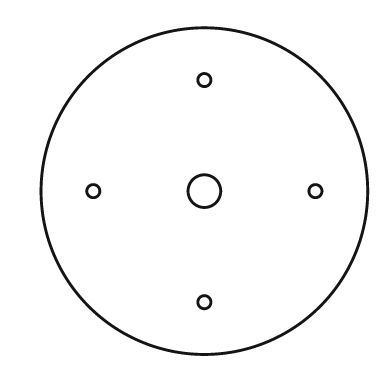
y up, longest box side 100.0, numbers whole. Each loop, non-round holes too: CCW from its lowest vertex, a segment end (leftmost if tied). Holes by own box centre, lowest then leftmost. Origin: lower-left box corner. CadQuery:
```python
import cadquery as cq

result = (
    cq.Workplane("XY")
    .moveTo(50.0, 50.0)
    .circle(50.0)
    .moveTo(50.0, 16.0)
    .circle(2.0)
    .moveTo(16.0, 50.0)
    .circle(2.0)
    .moveTo(50.0, 50.0)
    .circle(5.0)
    .moveTo(84.0, 50.0)
    .circle(2.0)
    .moveTo(50.0, 84.0)
    .circle(2.0)
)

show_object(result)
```